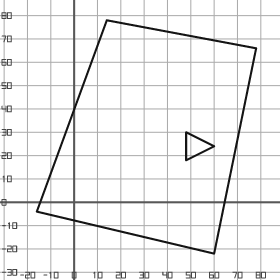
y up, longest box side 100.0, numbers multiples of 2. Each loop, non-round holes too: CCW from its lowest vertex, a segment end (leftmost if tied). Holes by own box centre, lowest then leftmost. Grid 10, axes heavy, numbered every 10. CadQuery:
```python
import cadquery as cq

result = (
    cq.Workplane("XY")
    .moveTo(60.0, -22.0)
    .lineTo(78.0, 66.0)
    .lineTo(14.0, 78.0)
    .lineTo(-16.0, -4.0)
    .close()
    .moveTo(48.0, 18.0)
    .lineTo(60.0, 24.0)
    .lineTo(48.0, 30.0)
    .close()
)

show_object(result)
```